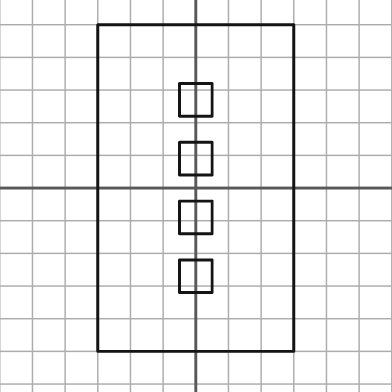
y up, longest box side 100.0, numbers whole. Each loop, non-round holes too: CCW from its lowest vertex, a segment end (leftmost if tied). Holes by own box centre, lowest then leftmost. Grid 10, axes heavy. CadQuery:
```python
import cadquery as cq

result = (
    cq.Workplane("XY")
    .moveTo(-30.0, -50.0)
    .lineTo(30.0, -50.0)
    .lineTo(30.0, 50.0)
    .lineTo(-30.0, 50.0)
    .close()
    .moveTo(-5.0, -32.0)
    .lineTo(5.0, -32.0)
    .lineTo(5.0, -22.0)
    .lineTo(-5.0, -22.0)
    .close()
    .moveTo(-5.0, -14.0)
    .lineTo(5.0, -14.0)
    .lineTo(5.0, -4.0)
    .lineTo(-5.0, -4.0)
    .close()
    .moveTo(-5.0, 4.0)
    .lineTo(5.0, 4.0)
    .lineTo(5.0, 14.0)
    .lineTo(-5.0, 14.0)
    .close()
    .moveTo(-5.0, 22.0)
    .lineTo(5.0, 22.0)
    .lineTo(5.0, 32.0)
    .lineTo(-5.0, 32.0)
    .close()
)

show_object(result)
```